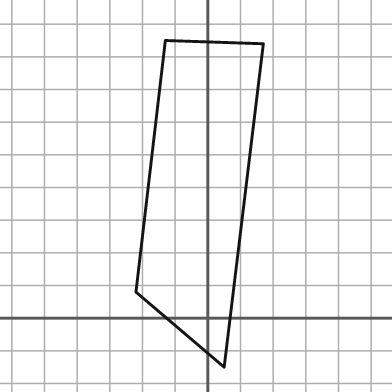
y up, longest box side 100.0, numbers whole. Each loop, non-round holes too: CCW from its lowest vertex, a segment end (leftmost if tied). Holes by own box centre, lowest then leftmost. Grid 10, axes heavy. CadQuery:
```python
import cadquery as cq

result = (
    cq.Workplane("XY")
    .moveTo(5.0, -15.0)
    .lineTo(17.0, 84.0)
    .lineTo(-13.0, 85.0)
    .lineTo(-22.0, 8.0)
    .close()
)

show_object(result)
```